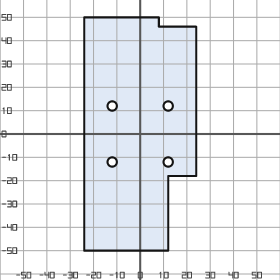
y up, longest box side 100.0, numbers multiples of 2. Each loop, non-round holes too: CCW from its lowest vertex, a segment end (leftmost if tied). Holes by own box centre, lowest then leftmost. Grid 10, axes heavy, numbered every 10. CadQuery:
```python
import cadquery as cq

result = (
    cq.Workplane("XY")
    .moveTo(-24.0, -50.0)
    .lineTo(12.0, -50.0)
    .lineTo(12.0, -18.0)
    .lineTo(24.0, -18.0)
    .lineTo(24.0, 46.0)
    .lineTo(8.0, 46.0)
    .lineTo(8.0, 50.0)
    .lineTo(-24.0, 50.0)
    .close()
    .moveTo(-12.0, -12.0)
    .circle(2.0)
    .moveTo(12.0, -12.0)
    .circle(2.0)
    .moveTo(-12.0, 12.0)
    .circle(2.0)
    .moveTo(12.0, 12.0)
    .circle(2.0)
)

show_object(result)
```